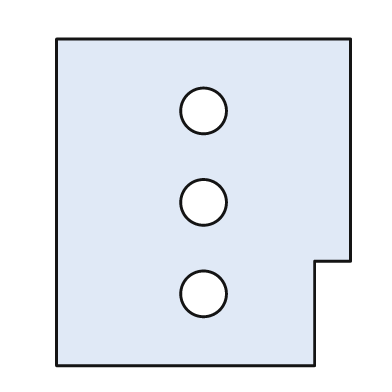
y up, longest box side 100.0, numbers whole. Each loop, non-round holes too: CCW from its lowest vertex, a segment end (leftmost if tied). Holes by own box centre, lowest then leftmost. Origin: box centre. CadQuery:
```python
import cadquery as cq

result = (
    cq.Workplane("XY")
    .moveTo(-45.0, -50.0)
    .lineTo(34.0, -50.0)
    .lineTo(34.0, -18.0)
    .lineTo(45.0, -18.0)
    .lineTo(45.0, 50.0)
    .lineTo(-45.0, 50.0)
    .close()
    .moveTo(0.0, -28.0)
    .circle(7.0)
    .moveTo(0.0, 0.0)
    .circle(7.0)
    .moveTo(0.0, 28.0)
    .circle(7.0)
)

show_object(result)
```